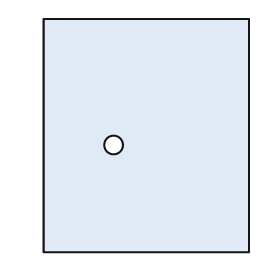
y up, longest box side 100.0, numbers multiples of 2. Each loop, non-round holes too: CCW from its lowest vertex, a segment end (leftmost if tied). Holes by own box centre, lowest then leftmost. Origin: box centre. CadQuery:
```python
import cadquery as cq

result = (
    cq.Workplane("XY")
    .moveTo(-44.0, -50.0)
    .lineTo(44.0, -50.0)
    .lineTo(44.0, 50.0)
    .lineTo(-44.0, 50.0)
    .close()
    .moveTo(-14.0, -4.0)
    .circle(4.0)
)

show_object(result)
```